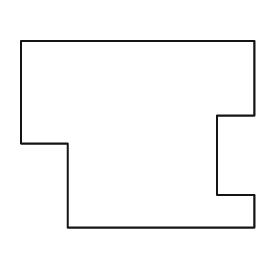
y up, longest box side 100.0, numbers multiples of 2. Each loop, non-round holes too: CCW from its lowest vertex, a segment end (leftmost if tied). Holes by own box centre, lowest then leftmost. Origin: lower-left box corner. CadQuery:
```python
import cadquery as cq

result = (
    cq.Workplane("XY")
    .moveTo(20.0, 0.0)
    .lineTo(100.0, 0.0)
    .lineTo(100.0, 14.0)
    .lineTo(84.0, 14.0)
    .lineTo(84.0, 48.0)
    .lineTo(100.0, 48.0)
    .lineTo(100.0, 80.0)
    .lineTo(0.0, 80.0)
    .lineTo(0.0, 36.0)
    .lineTo(20.0, 36.0)
    .close()
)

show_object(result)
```